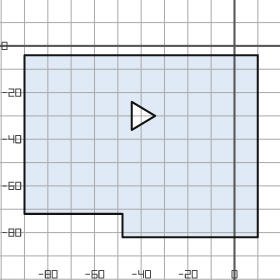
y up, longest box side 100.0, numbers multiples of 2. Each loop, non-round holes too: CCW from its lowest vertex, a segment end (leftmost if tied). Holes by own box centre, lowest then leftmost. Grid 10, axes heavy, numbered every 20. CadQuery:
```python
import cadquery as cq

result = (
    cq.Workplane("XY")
    .moveTo(-48.0, -82.0)
    .lineTo(10.0, -82.0)
    .lineTo(10.0, -4.0)
    .lineTo(-90.0, -4.0)
    .lineTo(-90.0, -72.0)
    .lineTo(-48.0, -72.0)
    .close()
    .moveTo(-44.0, -36.0)
    .lineTo(-34.0, -30.0)
    .lineTo(-44.0, -24.0)
    .close()
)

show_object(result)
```